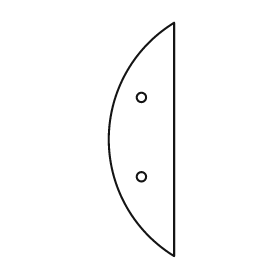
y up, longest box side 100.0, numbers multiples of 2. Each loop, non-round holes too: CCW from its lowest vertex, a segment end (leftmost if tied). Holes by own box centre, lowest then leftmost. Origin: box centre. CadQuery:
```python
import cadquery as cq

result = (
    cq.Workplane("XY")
    .moveTo(14.0, -50.0)
    .lineTo(14.0, 50.0)
    .threePointArc((-14.0, 0.0), (14.0, -50.0))
    .close()
    .moveTo(0.0, -16.0)
    .circle(2.0)
    .moveTo(0.0, 18.0)
    .circle(2.0)
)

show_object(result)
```